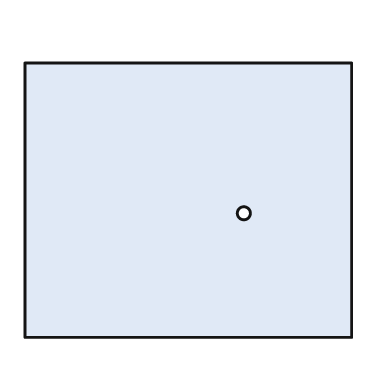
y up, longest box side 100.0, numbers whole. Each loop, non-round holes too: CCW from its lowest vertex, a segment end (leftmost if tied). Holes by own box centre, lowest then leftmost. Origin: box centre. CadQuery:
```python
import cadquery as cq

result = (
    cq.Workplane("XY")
    .moveTo(-50.0, -42.0)
    .lineTo(50.0, -42.0)
    .lineTo(50.0, 42.0)
    .lineTo(-50.0, 42.0)
    .close()
    .moveTo(17.0, -4.0)
    .circle(2.0)
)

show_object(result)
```